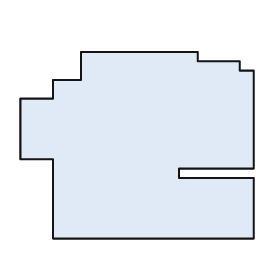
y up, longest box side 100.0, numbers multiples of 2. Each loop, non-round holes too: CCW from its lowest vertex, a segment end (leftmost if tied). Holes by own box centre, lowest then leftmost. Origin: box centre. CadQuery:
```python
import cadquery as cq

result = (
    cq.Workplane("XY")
    .moveTo(-36.0, -40.0)
    .lineTo(50.0, -40.0)
    .lineTo(50.0, -14.0)
    .lineTo(18.0, -14.0)
    .lineTo(18.0, -10.0)
    .lineTo(50.0, -10.0)
    .lineTo(50.0, 32.0)
    .lineTo(44.0, 32.0)
    .lineTo(44.0, 36.0)
    .lineTo(26.0, 36.0)
    .lineTo(26.0, 40.0)
    .lineTo(-24.0, 40.0)
    .lineTo(-24.0, 28.0)
    .lineTo(-36.0, 28.0)
    .lineTo(-36.0, 20.0)
    .lineTo(-50.0, 20.0)
    .lineTo(-50.0, -6.0)
    .lineTo(-36.0, -6.0)
    .close()
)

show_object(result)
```